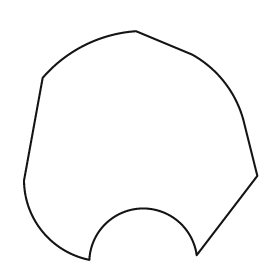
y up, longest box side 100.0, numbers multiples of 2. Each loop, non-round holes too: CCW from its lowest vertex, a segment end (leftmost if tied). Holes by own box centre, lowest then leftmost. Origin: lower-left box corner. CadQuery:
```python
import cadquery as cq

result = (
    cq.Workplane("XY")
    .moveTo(28.0, 0.0)
    .threePointArc((50.0, 22.0), (74.0, 2.0))
    .lineTo(100.0, 36.0)
    .lineTo(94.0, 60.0)
    .threePointArc((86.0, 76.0), (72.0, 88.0))
    .lineTo(48.0, 98.0)
    .threePointArc((26.0, 92.0), (8.0, 78.0))
    .lineTo(0.0, 34.0)
    .threePointArc((8.0, 12.0), (28.0, 0.0))
    .close()
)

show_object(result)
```